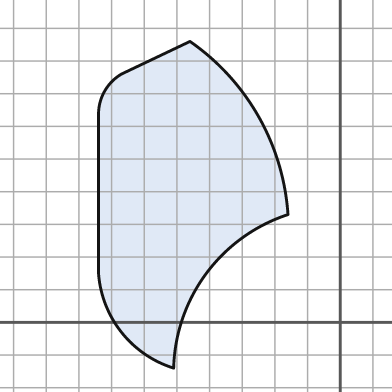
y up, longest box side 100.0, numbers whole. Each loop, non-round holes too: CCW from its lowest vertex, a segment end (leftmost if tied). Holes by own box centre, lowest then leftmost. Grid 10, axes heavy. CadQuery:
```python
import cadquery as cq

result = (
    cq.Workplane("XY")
    .moveTo(-51.0, -14.0)
    .threePointArc((-41.0, 15.0), (-16.0, 33.0))
    .threePointArc((-25.0, 63.0), (-46.0, 86.0))
    .lineTo(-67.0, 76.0)
    .threePointArc((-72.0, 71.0), (-74.0, 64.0))
    .lineTo(-74.0, 15.0)
    .threePointArc((-67.0, -3.0), (-51.0, -14.0))
    .close()
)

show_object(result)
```